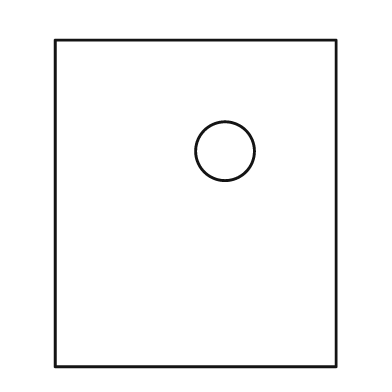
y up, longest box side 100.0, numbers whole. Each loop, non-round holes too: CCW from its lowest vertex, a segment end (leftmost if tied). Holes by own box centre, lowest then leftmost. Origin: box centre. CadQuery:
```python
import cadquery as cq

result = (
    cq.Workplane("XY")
    .moveTo(-43.0, -50.0)
    .lineTo(43.0, -50.0)
    .lineTo(43.0, 50.0)
    .lineTo(-43.0, 50.0)
    .close()
    .moveTo(9.0, 16.0)
    .circle(9.0)
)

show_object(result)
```